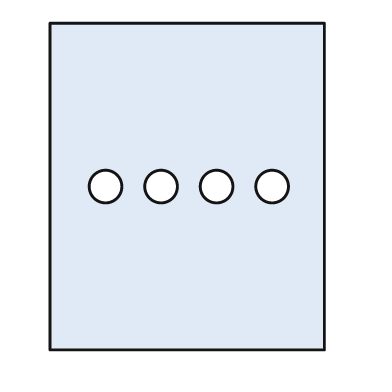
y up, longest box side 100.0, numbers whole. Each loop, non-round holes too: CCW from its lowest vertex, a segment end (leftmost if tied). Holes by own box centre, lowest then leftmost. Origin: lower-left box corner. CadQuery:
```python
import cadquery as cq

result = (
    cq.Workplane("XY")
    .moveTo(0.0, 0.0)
    .lineTo(84.0, 0.0)
    .lineTo(84.0, 100.0)
    .lineTo(0.0, 100.0)
    .close()
    .moveTo(17.0, 50.0)
    .circle(5.0)
    .moveTo(34.0, 50.0)
    .circle(5.0)
    .moveTo(51.0, 50.0)
    .circle(5.0)
    .moveTo(68.0, 50.0)
    .circle(5.0)
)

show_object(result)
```